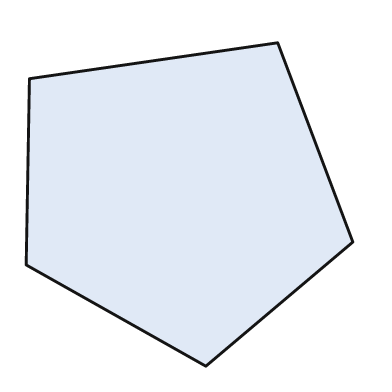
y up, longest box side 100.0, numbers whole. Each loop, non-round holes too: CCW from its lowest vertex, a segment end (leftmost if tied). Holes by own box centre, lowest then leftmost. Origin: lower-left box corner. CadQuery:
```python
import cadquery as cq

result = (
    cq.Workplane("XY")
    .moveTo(55.0, 0.0)
    .lineTo(100.0, 38.0)
    .lineTo(77.0, 99.0)
    .lineTo(1.0, 88.0)
    .lineTo(0.0, 31.0)
    .close()
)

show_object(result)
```